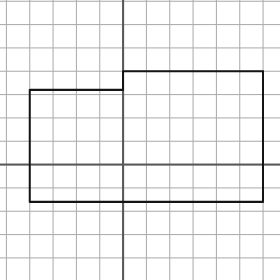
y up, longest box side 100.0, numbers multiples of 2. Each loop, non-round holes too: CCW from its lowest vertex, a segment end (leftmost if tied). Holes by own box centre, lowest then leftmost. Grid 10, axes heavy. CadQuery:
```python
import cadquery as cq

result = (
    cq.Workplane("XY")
    .moveTo(-40.0, -16.0)
    .lineTo(60.0, -16.0)
    .lineTo(60.0, 40.0)
    .lineTo(0.0, 40.0)
    .lineTo(0.0, 32.0)
    .lineTo(-40.0, 32.0)
    .close()
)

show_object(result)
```